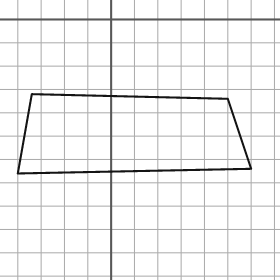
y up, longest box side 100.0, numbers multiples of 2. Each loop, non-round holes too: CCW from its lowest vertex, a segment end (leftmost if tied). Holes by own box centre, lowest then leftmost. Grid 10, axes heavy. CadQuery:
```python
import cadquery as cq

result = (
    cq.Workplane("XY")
    .moveTo(-40.0, -66.0)
    .lineTo(60.0, -64.0)
    .lineTo(50.0, -34.0)
    .lineTo(-34.0, -32.0)
    .close()
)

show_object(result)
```